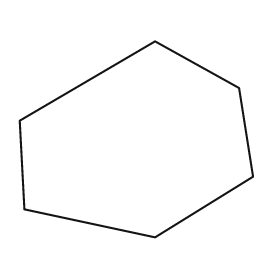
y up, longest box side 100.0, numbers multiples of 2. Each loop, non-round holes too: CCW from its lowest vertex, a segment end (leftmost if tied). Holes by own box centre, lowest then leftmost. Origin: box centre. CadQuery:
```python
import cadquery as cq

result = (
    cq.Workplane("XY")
    .moveTo(8.0, -42.0)
    .lineTo(50.0, -16.0)
    .lineTo(44.0, 22.0)
    .lineTo(8.0, 42.0)
    .lineTo(-50.0, 8.0)
    .lineTo(-48.0, -30.0)
    .close()
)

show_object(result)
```